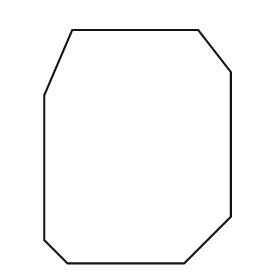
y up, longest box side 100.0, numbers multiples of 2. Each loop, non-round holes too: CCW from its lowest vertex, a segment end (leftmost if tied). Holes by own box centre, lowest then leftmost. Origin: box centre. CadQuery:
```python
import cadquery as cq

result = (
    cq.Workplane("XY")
    .moveTo(-30.0, -50.0)
    .lineTo(20.0, -50.0)
    .lineTo(40.0, -30.0)
    .lineTo(40.0, 32.0)
    .lineTo(26.0, 50.0)
    .lineTo(-28.0, 50.0)
    .lineTo(-40.0, 22.0)
    .lineTo(-40.0, -40.0)
    .close()
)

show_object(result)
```